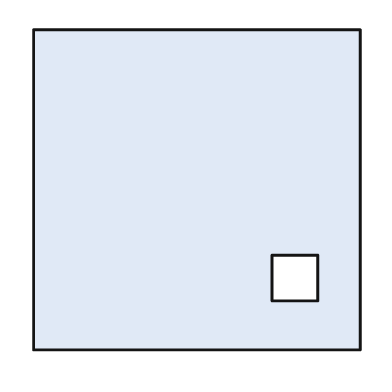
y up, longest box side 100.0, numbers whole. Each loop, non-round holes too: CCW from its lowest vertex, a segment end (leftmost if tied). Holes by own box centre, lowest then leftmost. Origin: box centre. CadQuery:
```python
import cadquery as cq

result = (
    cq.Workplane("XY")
    .moveTo(-50.0, -49.0)
    .lineTo(50.0, -49.0)
    .lineTo(50.0, 49.0)
    .lineTo(-50.0, 49.0)
    .close()
    .moveTo(23.0, -34.0)
    .lineTo(37.0, -34.0)
    .lineTo(37.0, -20.0)
    .lineTo(23.0, -20.0)
    .close()
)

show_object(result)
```